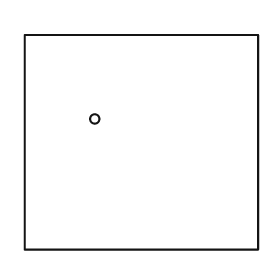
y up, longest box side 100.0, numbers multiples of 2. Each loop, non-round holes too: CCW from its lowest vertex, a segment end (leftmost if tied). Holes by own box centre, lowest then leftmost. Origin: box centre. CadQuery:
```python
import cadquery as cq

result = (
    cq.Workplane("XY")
    .moveTo(-50.0, -46.0)
    .lineTo(50.0, -46.0)
    .lineTo(50.0, 46.0)
    .lineTo(-50.0, 46.0)
    .close()
    .moveTo(-20.0, 10.0)
    .circle(2.0)
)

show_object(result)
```